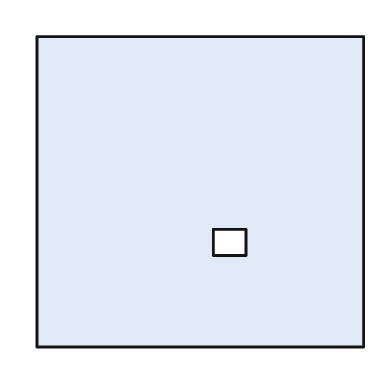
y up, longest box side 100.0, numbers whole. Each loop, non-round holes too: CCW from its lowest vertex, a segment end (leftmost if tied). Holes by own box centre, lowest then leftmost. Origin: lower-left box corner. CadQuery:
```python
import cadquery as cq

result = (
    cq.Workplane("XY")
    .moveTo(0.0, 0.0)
    .lineTo(100.0, 0.0)
    .lineTo(100.0, 95.0)
    .lineTo(0.0, 95.0)
    .close()
    .moveTo(54.0, 28.0)
    .lineTo(64.0, 28.0)
    .lineTo(64.0, 36.0)
    .lineTo(54.0, 36.0)
    .close()
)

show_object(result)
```